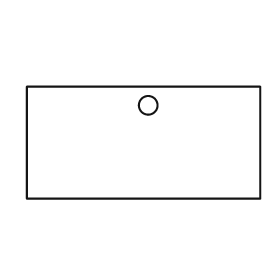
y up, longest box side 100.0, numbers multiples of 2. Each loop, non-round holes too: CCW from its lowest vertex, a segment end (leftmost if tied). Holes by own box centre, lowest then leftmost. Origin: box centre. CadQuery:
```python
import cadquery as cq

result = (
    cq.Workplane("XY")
    .moveTo(-50.0, -24.0)
    .lineTo(50.0, -24.0)
    .lineTo(50.0, 24.0)
    .lineTo(-50.0, 24.0)
    .close()
    .moveTo(2.0, 16.0)
    .circle(4.0)
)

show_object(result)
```